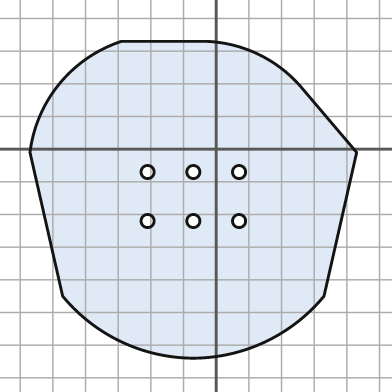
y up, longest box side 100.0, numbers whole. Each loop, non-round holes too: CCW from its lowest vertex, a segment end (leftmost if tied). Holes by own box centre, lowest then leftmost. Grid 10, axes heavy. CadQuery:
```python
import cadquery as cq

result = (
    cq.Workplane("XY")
    .moveTo(-7.0, -64.0)
    .threePointArc((15.0, -59.0), (33.0, -45.0))
    .lineTo(43.0, -1.0)
    .lineTo(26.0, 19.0)
    .threePointArc((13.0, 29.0), (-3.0, 33.0))
    .lineTo(-29.0, 33.0)
    .threePointArc((-48.0, 20.0), (-57.0, -1.0))
    .lineTo(-47.0, -45.0)
    .threePointArc((-29.0, -59.0), (-7.0, -64.0))
    .close()
    .moveTo(-21.0, -22.0)
    .circle(2.0)
    .moveTo(-7.0, -22.0)
    .circle(2.0)
    .moveTo(7.0, -22.0)
    .circle(2.0)
    .moveTo(-21.0, -7.0)
    .circle(2.0)
    .moveTo(-7.0, -7.0)
    .circle(2.0)
    .moveTo(7.0, -7.0)
    .circle(2.0)
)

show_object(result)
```